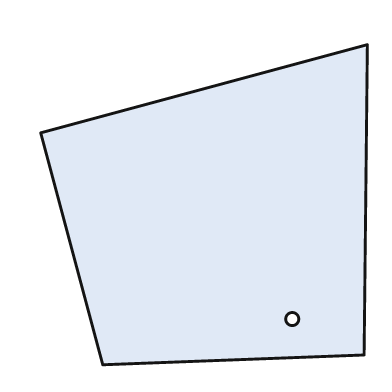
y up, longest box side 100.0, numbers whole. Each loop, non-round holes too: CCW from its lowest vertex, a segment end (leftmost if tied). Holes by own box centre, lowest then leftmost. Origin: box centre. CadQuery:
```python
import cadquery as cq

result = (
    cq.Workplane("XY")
    .moveTo(-31.0, -49.0)
    .lineTo(49.0, -46.0)
    .lineTo(50.0, 49.0)
    .lineTo(-50.0, 22.0)
    .close()
    .moveTo(27.0, -35.0)
    .circle(2.0)
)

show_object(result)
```